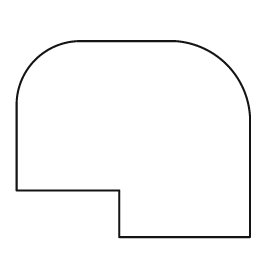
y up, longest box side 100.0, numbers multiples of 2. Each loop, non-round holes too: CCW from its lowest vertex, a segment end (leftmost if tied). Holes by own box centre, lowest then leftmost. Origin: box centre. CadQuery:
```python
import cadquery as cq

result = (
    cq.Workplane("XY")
    .moveTo(-6.0, -42.0)
    .lineTo(50.0, -42.0)
    .lineTo(50.0, 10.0)
    .threePointArc((40.0, 32.0), (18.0, 42.0))
    .lineTo(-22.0, 42.0)
    .threePointArc((-42.0, 34.0), (-50.0, 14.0))
    .lineTo(-50.0, -22.0)
    .lineTo(-6.0, -22.0)
    .close()
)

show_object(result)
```